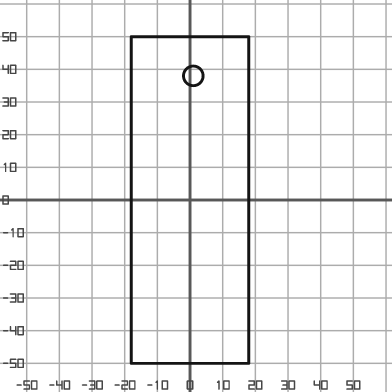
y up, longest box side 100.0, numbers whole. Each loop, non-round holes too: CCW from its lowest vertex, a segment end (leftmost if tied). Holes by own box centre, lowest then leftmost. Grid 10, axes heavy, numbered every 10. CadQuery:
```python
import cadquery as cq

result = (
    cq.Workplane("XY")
    .moveTo(-18.0, -50.0)
    .lineTo(18.0, -50.0)
    .lineTo(18.0, 50.0)
    .lineTo(-18.0, 50.0)
    .close()
    .moveTo(1.0, 38.0)
    .circle(3.0)
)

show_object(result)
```